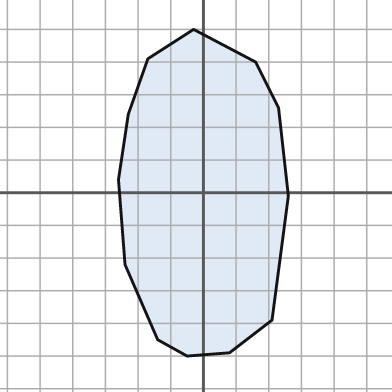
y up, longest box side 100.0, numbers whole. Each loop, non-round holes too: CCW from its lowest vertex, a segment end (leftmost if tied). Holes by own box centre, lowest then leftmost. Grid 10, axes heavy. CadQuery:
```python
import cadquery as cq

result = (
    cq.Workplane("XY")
    .moveTo(-5.0, -50.0)
    .lineTo(8.0, -49.0)
    .lineTo(21.0, -39.0)
    .lineTo(26.0, -1.0)
    .lineTo(23.0, 26.0)
    .lineTo(16.0, 40.0)
    .lineTo(-3.0, 50.0)
    .lineTo(-17.0, 41.0)
    .lineTo(-23.0, 24.0)
    .lineTo(-26.0, 4.0)
    .lineTo(-24.0, -22.0)
    .lineTo(-14.0, -45.0)
    .close()
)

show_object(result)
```